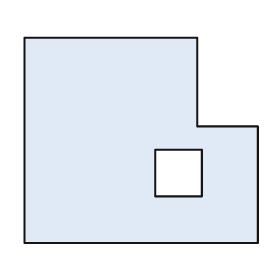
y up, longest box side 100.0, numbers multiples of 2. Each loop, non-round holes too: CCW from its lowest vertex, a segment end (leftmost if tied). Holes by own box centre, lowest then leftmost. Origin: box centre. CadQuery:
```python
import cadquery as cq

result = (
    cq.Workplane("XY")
    .moveTo(-50.0, -44.0)
    .lineTo(50.0, -44.0)
    .lineTo(50.0, 6.0)
    .lineTo(24.0, 6.0)
    .lineTo(24.0, 44.0)
    .lineTo(-50.0, 44.0)
    .close()
    .moveTo(6.0, -24.0)
    .lineTo(26.0, -24.0)
    .lineTo(26.0, -4.0)
    .lineTo(6.0, -4.0)
    .close()
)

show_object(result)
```